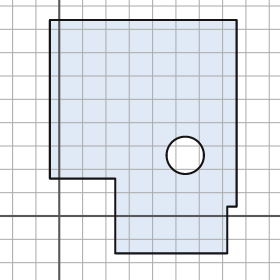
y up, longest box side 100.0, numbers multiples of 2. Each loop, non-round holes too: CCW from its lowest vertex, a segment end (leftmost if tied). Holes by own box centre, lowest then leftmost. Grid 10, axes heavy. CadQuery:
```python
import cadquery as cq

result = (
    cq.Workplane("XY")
    .moveTo(24.0, -16.0)
    .lineTo(72.0, -16.0)
    .lineTo(72.0, 4.0)
    .lineTo(76.0, 4.0)
    .lineTo(76.0, 84.0)
    .lineTo(-4.0, 84.0)
    .lineTo(-4.0, 16.0)
    .lineTo(24.0, 16.0)
    .close()
    .moveTo(54.0, 26.0)
    .circle(8.0)
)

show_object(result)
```